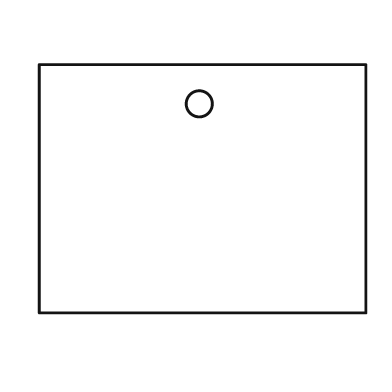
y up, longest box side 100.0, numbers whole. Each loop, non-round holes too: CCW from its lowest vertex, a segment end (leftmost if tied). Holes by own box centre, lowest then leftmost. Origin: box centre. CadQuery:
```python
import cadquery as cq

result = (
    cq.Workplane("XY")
    .moveTo(-50.0, -38.0)
    .lineTo(50.0, -38.0)
    .lineTo(50.0, 38.0)
    .lineTo(-50.0, 38.0)
    .close()
    .moveTo(-1.0, 26.0)
    .circle(4.0)
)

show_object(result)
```